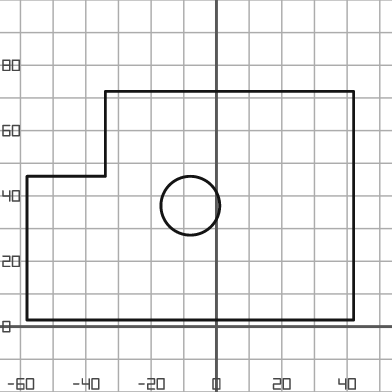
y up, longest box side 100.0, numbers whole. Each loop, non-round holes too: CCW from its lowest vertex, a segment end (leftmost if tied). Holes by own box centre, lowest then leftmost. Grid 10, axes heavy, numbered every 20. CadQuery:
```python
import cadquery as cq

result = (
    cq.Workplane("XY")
    .moveTo(-58.0, 2.0)
    .lineTo(42.0, 2.0)
    .lineTo(42.0, 72.0)
    .lineTo(-34.0, 72.0)
    .lineTo(-34.0, 46.0)
    .lineTo(-58.0, 46.0)
    .close()
    .moveTo(-8.0, 37.0)
    .circle(9.0)
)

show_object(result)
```